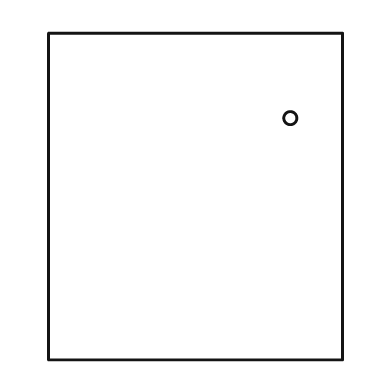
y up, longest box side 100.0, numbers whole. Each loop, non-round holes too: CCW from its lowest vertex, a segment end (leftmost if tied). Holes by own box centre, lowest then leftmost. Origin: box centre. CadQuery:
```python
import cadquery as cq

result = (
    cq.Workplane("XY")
    .moveTo(-45.0, -50.0)
    .lineTo(45.0, -50.0)
    .lineTo(45.0, 50.0)
    .lineTo(-45.0, 50.0)
    .close()
    .moveTo(29.0, 24.0)
    .circle(2.0)
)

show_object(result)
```